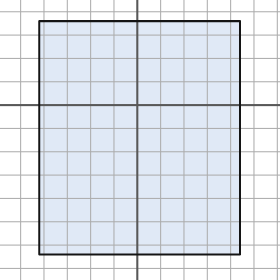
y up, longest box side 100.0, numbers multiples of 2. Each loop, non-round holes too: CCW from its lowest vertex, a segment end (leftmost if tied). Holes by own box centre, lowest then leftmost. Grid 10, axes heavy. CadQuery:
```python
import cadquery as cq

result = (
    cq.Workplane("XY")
    .moveTo(-42.0, -64.0)
    .lineTo(44.0, -64.0)
    .lineTo(44.0, 36.0)
    .lineTo(-42.0, 36.0)
    .close()
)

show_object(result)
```